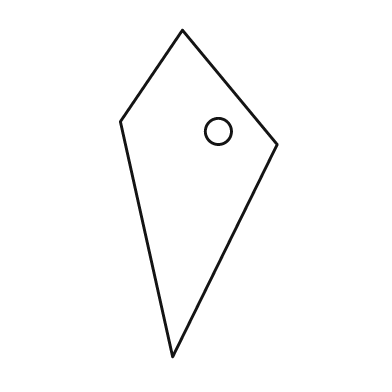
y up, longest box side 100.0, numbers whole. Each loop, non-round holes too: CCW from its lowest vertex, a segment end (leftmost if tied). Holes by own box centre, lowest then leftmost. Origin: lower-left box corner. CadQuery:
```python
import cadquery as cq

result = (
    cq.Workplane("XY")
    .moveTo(16.0, 0.0)
    .lineTo(48.0, 65.0)
    .lineTo(19.0, 100.0)
    .lineTo(0.0, 72.0)
    .close()
    .moveTo(30.0, 69.0)
    .circle(4.0)
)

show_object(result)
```